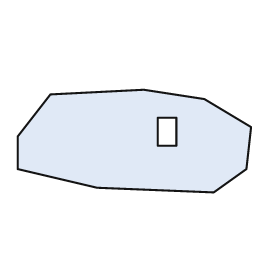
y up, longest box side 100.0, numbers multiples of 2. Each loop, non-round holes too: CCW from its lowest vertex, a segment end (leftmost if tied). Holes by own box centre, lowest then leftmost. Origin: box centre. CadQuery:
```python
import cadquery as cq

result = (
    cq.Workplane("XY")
    .moveTo(34.0, -22.0)
    .lineTo(48.0, -12.0)
    .lineTo(50.0, 6.0)
    .lineTo(30.0, 18.0)
    .lineTo(4.0, 22.0)
    .lineTo(-36.0, 20.0)
    .lineTo(-50.0, 2.0)
    .lineTo(-50.0, -12.0)
    .lineTo(-16.0, -20.0)
    .close()
    .moveTo(10.0, -2.0)
    .lineTo(18.0, -2.0)
    .lineTo(18.0, 10.0)
    .lineTo(10.0, 10.0)
    .close()
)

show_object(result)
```